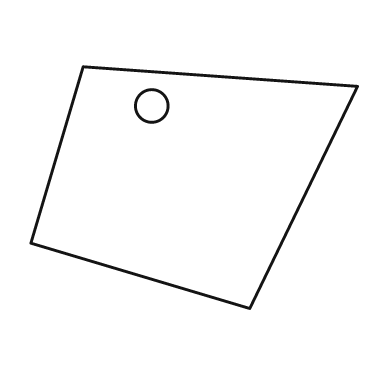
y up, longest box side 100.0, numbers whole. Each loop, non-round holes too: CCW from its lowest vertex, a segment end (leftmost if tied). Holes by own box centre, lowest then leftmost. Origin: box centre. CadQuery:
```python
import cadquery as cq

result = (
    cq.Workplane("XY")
    .moveTo(17.0, -37.0)
    .lineTo(50.0, 31.0)
    .lineTo(-34.0, 37.0)
    .lineTo(-50.0, -17.0)
    .close()
    .moveTo(-13.0, 25.0)
    .circle(5.0)
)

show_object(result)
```